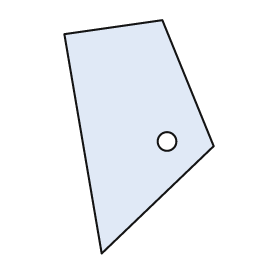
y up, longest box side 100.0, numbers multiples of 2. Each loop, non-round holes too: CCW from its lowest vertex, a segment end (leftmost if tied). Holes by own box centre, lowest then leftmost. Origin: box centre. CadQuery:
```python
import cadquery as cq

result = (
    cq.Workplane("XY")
    .moveTo(-16.0, -50.0)
    .lineTo(32.0, -4.0)
    .lineTo(10.0, 50.0)
    .lineTo(-32.0, 44.0)
    .close()
    .moveTo(12.0, -2.0)
    .circle(4.0)
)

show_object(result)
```